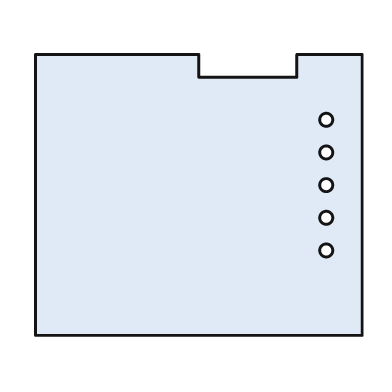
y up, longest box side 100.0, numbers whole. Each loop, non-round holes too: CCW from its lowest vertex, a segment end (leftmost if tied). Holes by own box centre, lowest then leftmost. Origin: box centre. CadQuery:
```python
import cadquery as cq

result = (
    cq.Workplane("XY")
    .moveTo(-50.0, -43.0)
    .lineTo(50.0, -43.0)
    .lineTo(50.0, 43.0)
    .lineTo(30.0, 43.0)
    .lineTo(30.0, 36.0)
    .lineTo(0.0, 36.0)
    .lineTo(0.0, 43.0)
    .lineTo(-50.0, 43.0)
    .close()
    .moveTo(39.0, -17.0)
    .circle(2.0)
    .moveTo(39.0, -7.0)
    .circle(2.0)
    .moveTo(39.0, 3.0)
    .circle(2.0)
    .moveTo(39.0, 13.0)
    .circle(2.0)
    .moveTo(39.0, 23.0)
    .circle(2.0)
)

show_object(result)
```